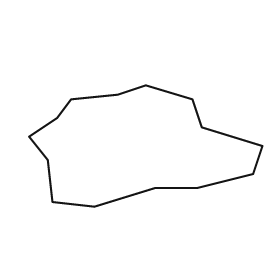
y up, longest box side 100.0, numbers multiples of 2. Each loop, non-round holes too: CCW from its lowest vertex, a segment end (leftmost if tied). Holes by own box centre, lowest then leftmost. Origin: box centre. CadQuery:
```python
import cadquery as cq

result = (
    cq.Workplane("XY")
    .moveTo(-22.0, -26.0)
    .lineTo(4.0, -18.0)
    .lineTo(22.0, -18.0)
    .lineTo(46.0, -12.0)
    .lineTo(50.0, 0.0)
    .lineTo(24.0, 8.0)
    .lineTo(20.0, 20.0)
    .lineTo(0.0, 26.0)
    .lineTo(-12.0, 22.0)
    .lineTo(-32.0, 20.0)
    .lineTo(-38.0, 12.0)
    .lineTo(-50.0, 4.0)
    .lineTo(-42.0, -6.0)
    .lineTo(-40.0, -24.0)
    .close()
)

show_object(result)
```